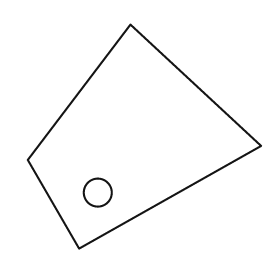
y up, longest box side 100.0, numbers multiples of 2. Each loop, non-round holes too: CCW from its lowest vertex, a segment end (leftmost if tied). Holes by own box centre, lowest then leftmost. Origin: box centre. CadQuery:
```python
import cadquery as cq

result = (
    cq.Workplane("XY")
    .moveTo(-28.0, -48.0)
    .lineTo(50.0, -4.0)
    .lineTo(-6.0, 48.0)
    .lineTo(-50.0, -10.0)
    .close()
    .moveTo(-20.0, -24.0)
    .circle(6.0)
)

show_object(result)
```